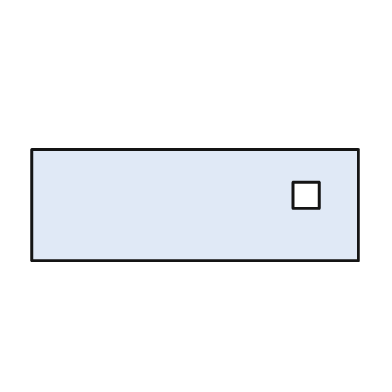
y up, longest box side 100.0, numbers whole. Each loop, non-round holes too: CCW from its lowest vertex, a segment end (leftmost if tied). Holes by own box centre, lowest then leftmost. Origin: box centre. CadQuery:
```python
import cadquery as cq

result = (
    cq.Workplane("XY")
    .moveTo(-50.0, -17.0)
    .lineTo(50.0, -17.0)
    .lineTo(50.0, 17.0)
    .lineTo(-50.0, 17.0)
    .close()
    .moveTo(30.0, -1.0)
    .lineTo(38.0, -1.0)
    .lineTo(38.0, 7.0)
    .lineTo(30.0, 7.0)
    .close()
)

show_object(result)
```